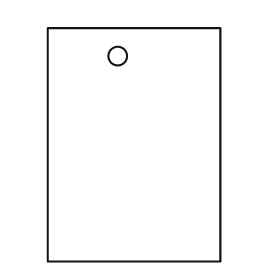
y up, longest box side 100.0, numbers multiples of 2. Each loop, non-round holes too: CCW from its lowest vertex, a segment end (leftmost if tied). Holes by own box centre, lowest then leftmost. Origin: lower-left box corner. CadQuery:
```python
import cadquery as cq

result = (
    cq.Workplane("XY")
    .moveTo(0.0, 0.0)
    .lineTo(74.0, 0.0)
    .lineTo(74.0, 100.0)
    .lineTo(0.0, 100.0)
    .close()
    .moveTo(30.0, 88.0)
    .circle(4.0)
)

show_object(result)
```